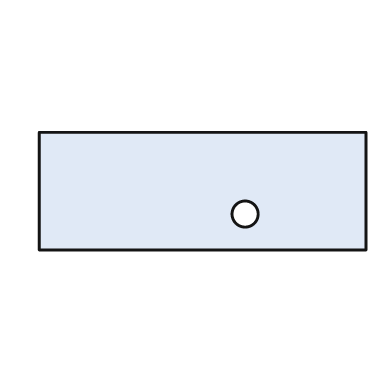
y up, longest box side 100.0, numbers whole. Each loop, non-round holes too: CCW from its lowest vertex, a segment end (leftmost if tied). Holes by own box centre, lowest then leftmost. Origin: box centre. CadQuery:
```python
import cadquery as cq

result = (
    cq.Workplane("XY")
    .moveTo(-50.0, -18.0)
    .lineTo(50.0, -18.0)
    .lineTo(50.0, 18.0)
    .lineTo(-50.0, 18.0)
    .close()
    .moveTo(13.0, -7.0)
    .circle(4.0)
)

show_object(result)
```